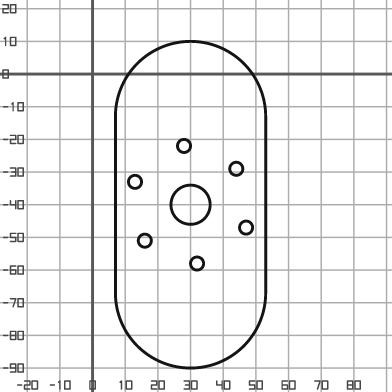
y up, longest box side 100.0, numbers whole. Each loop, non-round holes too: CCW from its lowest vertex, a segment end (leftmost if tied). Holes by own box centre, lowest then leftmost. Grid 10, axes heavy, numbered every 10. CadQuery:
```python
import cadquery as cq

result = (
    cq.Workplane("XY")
    .moveTo(7.0, -67.0)
    .threePointArc((30.0, -90.0), (53.0, -67.0))
    .lineTo(53.0, -13.0)
    .threePointArc((30.0, 10.0), (7.0, -13.0))
    .close()
    .moveTo(32.0, -58.0)
    .circle(2.0)
    .moveTo(16.0, -51.0)
    .circle(2.0)
    .moveTo(47.0, -47.0)
    .circle(2.0)
    .moveTo(30.0, -40.0)
    .circle(6.0)
    .moveTo(13.0, -33.0)
    .circle(2.0)
    .moveTo(44.0, -29.0)
    .circle(2.0)
    .moveTo(28.0, -22.0)
    .circle(2.0)
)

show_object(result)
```